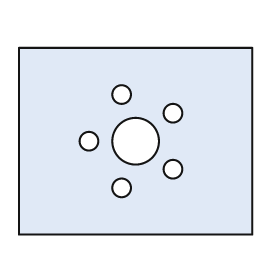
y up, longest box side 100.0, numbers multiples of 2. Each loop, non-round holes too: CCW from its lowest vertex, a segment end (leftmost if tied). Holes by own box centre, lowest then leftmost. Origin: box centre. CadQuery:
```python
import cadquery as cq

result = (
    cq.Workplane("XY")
    .moveTo(-50.0, -40.0)
    .lineTo(50.0, -40.0)
    .lineTo(50.0, 40.0)
    .lineTo(-50.0, 40.0)
    .close()
    .moveTo(-6.0, -20.0)
    .circle(4.0)
    .moveTo(16.0, -12.0)
    .circle(4.0)
    .moveTo(-20.0, 0.0)
    .circle(4.0)
    .moveTo(0.0, 0.0)
    .circle(10.0)
    .moveTo(16.0, 12.0)
    .circle(4.0)
    .moveTo(-6.0, 20.0)
    .circle(4.0)
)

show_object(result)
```